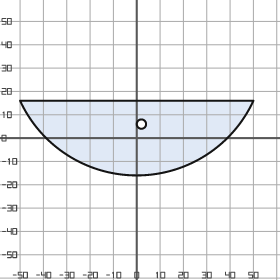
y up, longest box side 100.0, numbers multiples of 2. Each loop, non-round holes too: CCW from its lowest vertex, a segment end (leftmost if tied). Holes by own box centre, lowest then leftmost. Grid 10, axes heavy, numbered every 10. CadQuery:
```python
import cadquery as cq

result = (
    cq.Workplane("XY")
    .moveTo(-50.0, 16.0)
    .threePointArc((0.0, -16.0), (50.0, 16.0))
    .close()
    .moveTo(2.0, 6.0)
    .circle(2.0)
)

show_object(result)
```